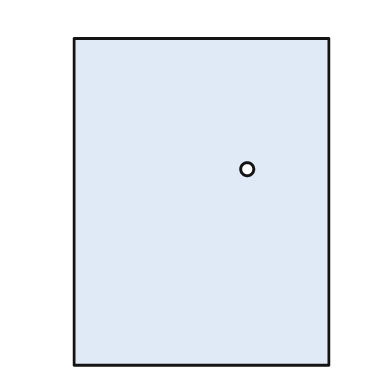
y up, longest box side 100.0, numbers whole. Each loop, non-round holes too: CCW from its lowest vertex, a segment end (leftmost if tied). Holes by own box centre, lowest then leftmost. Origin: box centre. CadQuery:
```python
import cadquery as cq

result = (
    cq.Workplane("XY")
    .moveTo(-39.0, -50.0)
    .lineTo(39.0, -50.0)
    .lineTo(39.0, 50.0)
    .lineTo(-39.0, 50.0)
    .close()
    .moveTo(14.0, 10.0)
    .circle(2.0)
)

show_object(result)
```